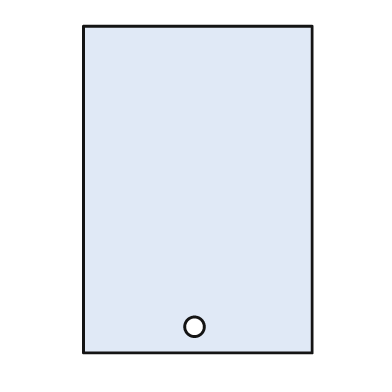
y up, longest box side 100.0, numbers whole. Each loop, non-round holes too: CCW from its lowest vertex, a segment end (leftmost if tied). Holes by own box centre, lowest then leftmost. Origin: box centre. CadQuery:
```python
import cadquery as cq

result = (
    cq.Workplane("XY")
    .moveTo(-35.0, -50.0)
    .lineTo(35.0, -50.0)
    .lineTo(35.0, 50.0)
    .lineTo(-35.0, 50.0)
    .close()
    .moveTo(-1.0, -42.0)
    .circle(3.0)
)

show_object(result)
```